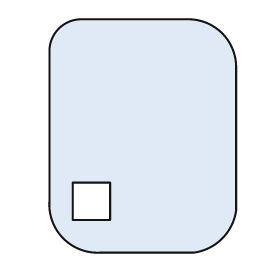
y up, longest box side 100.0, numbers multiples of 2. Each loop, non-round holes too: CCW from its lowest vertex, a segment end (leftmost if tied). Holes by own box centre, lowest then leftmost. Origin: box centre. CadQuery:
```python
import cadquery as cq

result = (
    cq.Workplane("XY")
    .moveTo(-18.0, -50.0)
    .lineTo(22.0, -50.0)
    .threePointArc((34.0, -44.0), (40.0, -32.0))
    .lineTo(40.0, 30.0)
    .threePointArc((34.0, 44.0), (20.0, 50.0))
    .lineTo(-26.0, 50.0)
    .threePointArc((-36.0, 46.0), (-40.0, 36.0))
    .lineTo(-40.0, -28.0)
    .threePointArc((-34.0, -44.0), (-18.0, -50.0))
    .close()
    .moveTo(-30.0, -36.0)
    .lineTo(-14.0, -36.0)
    .lineTo(-14.0, -20.0)
    .lineTo(-30.0, -20.0)
    .close()
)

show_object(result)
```